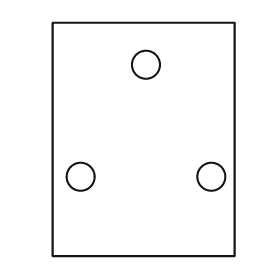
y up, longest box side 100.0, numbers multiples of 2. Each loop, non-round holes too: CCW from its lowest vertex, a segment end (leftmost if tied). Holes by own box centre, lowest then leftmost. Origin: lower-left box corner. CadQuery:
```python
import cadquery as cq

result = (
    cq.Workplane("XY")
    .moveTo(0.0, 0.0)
    .lineTo(78.0, 0.0)
    .lineTo(78.0, 100.0)
    .lineTo(0.0, 100.0)
    .close()
    .moveTo(12.0, 34.0)
    .circle(6.0)
    .moveTo(68.0, 34.0)
    .circle(6.0)
    .moveTo(40.0, 82.0)
    .circle(6.0)
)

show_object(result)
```